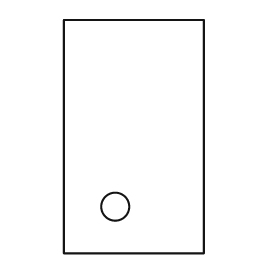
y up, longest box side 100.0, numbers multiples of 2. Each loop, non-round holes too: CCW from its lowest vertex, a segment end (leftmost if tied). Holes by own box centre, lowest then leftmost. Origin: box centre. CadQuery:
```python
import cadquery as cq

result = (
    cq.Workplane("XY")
    .moveTo(-30.0, -50.0)
    .lineTo(30.0, -50.0)
    .lineTo(30.0, 50.0)
    .lineTo(-30.0, 50.0)
    .close()
    .moveTo(-8.0, -30.0)
    .circle(6.0)
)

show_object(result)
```